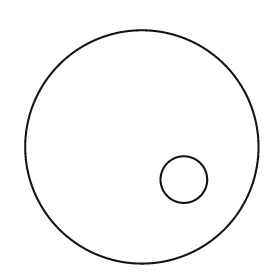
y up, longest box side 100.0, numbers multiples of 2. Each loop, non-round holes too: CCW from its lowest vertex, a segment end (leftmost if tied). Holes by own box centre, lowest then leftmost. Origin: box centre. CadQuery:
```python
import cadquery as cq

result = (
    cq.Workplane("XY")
    .moveTo(0.0, 0.0)
    .circle(50.0)
    .moveTo(18.0, -14.0)
    .circle(10.0)
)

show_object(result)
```